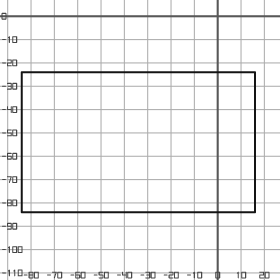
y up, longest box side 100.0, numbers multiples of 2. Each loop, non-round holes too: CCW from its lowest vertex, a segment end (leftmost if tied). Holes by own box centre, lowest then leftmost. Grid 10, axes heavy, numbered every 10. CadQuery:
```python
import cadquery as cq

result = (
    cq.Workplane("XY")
    .moveTo(-84.0, -84.0)
    .lineTo(16.0, -84.0)
    .lineTo(16.0, -24.0)
    .lineTo(-84.0, -24.0)
    .close()
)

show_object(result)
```